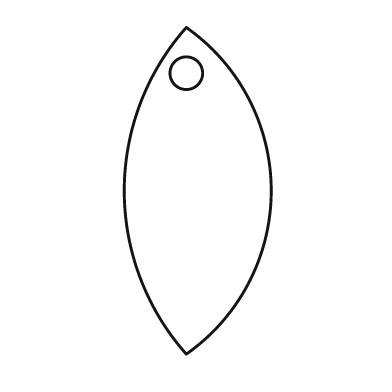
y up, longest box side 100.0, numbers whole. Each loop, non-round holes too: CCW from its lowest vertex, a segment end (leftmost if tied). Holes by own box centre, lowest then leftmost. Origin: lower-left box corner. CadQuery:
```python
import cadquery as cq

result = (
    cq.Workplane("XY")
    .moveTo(19.0, 0.0)
    .threePointArc((45.0, 50.0), (19.0, 100.0))
    .threePointArc((0.0, 50.0), (19.0, 0.0))
    .close()
    .moveTo(19.0, 86.0)
    .circle(5.0)
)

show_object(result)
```